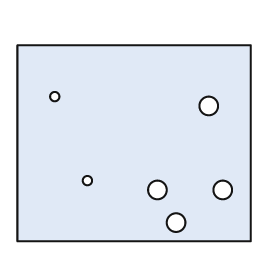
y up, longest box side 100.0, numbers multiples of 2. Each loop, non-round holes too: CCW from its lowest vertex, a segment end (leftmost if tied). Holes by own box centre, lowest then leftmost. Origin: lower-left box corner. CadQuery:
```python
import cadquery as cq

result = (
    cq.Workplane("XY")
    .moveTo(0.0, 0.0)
    .lineTo(100.0, 0.0)
    .lineTo(100.0, 84.0)
    .lineTo(0.0, 84.0)
    .close()
    .moveTo(68.0, 8.0)
    .circle(4.0)
    .moveTo(60.0, 22.0)
    .circle(4.0)
    .moveTo(88.0, 22.0)
    .circle(4.0)
    .moveTo(30.0, 26.0)
    .circle(2.0)
    .moveTo(82.0, 58.0)
    .circle(4.0)
    .moveTo(16.0, 62.0)
    .circle(2.0)
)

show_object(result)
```